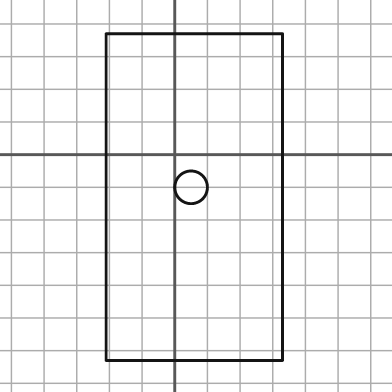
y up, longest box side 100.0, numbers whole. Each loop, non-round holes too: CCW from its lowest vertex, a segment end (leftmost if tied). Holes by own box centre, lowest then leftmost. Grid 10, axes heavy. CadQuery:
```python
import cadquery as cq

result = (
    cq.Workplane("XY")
    .moveTo(-21.0, -63.0)
    .lineTo(33.0, -63.0)
    .lineTo(33.0, 37.0)
    .lineTo(-21.0, 37.0)
    .close()
    .moveTo(5.0, -10.0)
    .circle(5.0)
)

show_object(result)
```